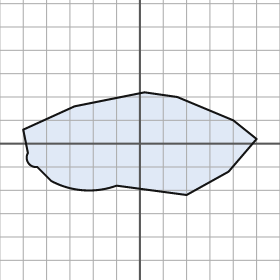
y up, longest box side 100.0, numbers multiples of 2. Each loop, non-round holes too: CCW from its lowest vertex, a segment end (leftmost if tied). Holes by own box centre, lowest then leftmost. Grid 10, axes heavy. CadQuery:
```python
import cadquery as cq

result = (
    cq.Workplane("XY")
    .moveTo(20.0, -22.0)
    .lineTo(38.0, -12.0)
    .lineTo(50.0, 2.0)
    .lineTo(40.0, 10.0)
    .lineTo(16.0, 20.0)
    .lineTo(2.0, 22.0)
    .lineTo(-28.0, 16.0)
    .lineTo(-50.0, 6.0)
    .lineTo(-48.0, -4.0)
    .threePointArc((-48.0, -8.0), (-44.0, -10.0))
    .lineTo(-38.0, -16.0)
    .threePointArc((-24.0, -20.0), (-10.0, -18.0))
    .close()
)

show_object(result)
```